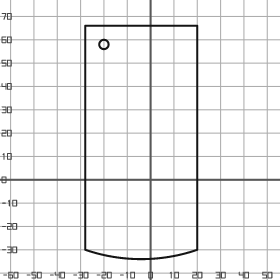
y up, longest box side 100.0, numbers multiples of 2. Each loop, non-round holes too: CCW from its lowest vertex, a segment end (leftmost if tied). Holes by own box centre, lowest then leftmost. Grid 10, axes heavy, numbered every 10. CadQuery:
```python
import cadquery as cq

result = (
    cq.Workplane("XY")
    .moveTo(-28.0, -30.0)
    .threePointArc((-4.0, -34.0), (20.0, -30.0))
    .lineTo(20.0, 66.0)
    .lineTo(-28.0, 66.0)
    .close()
    .moveTo(-20.0, 58.0)
    .circle(2.0)
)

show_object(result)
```